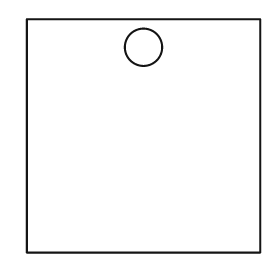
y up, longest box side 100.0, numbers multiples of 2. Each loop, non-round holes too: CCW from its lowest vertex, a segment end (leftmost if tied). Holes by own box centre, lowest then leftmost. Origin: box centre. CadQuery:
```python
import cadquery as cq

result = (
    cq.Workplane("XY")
    .moveTo(-50.0, -50.0)
    .lineTo(50.0, -50.0)
    .lineTo(50.0, 50.0)
    .lineTo(-50.0, 50.0)
    .close()
    .moveTo(0.0, 38.0)
    .circle(8.0)
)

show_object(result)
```